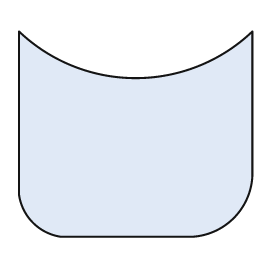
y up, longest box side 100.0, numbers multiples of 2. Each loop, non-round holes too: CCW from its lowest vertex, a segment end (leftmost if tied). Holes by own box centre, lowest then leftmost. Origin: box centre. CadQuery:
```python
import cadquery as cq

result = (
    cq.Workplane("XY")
    .moveTo(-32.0, -44.0)
    .lineTo(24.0, -44.0)
    .threePointArc((42.0, -36.0), (50.0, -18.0))
    .lineTo(50.0, 44.0)
    .threePointArc((0.0, 24.0), (-50.0, 44.0))
    .lineTo(-50.0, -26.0)
    .threePointArc((-44.0, -38.0), (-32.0, -44.0))
    .close()
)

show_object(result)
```